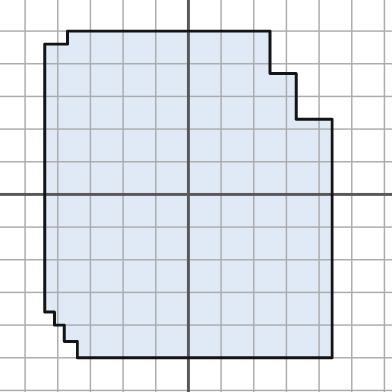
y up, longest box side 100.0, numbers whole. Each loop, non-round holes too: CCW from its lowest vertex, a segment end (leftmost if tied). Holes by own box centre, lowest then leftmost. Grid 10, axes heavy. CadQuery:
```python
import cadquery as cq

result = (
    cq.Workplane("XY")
    .moveTo(-34.0, -50.0)
    .lineTo(44.0, -50.0)
    .lineTo(44.0, 23.0)
    .lineTo(33.0, 23.0)
    .lineTo(33.0, 37.0)
    .lineTo(25.0, 37.0)
    .lineTo(25.0, 50.0)
    .lineTo(-37.0, 50.0)
    .lineTo(-37.0, 46.0)
    .lineTo(-44.0, 46.0)
    .lineTo(-44.0, -36.0)
    .lineTo(-41.0, -36.0)
    .lineTo(-41.0, -40.0)
    .lineTo(-38.0, -40.0)
    .lineTo(-38.0, -45.0)
    .lineTo(-34.0, -45.0)
    .close()
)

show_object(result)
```